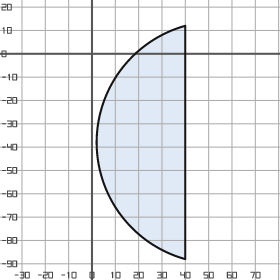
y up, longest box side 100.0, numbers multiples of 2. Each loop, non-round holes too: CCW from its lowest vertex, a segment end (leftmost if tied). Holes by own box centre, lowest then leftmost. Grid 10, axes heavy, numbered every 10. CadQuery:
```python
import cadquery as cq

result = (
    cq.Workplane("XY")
    .moveTo(40.0, -88.0)
    .lineTo(40.0, 12.0)
    .threePointArc((2.0, -38.0), (40.0, -88.0))
    .close()
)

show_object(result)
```